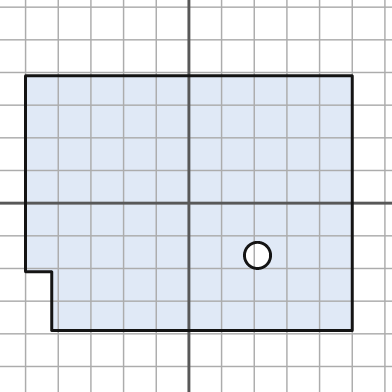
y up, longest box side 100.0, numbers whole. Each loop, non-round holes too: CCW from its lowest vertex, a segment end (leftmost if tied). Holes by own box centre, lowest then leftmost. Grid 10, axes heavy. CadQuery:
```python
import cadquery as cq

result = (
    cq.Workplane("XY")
    .moveTo(-42.0, -39.0)
    .lineTo(50.0, -39.0)
    .lineTo(50.0, 39.0)
    .lineTo(-50.0, 39.0)
    .lineTo(-50.0, -21.0)
    .lineTo(-42.0, -21.0)
    .close()
    .moveTo(21.0, -16.0)
    .circle(4.0)
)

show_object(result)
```